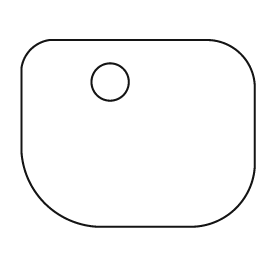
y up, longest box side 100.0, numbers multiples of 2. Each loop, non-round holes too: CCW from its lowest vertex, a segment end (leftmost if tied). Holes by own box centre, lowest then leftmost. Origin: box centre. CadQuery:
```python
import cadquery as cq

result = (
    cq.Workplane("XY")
    .moveTo(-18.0, -40.0)
    .lineTo(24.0, -40.0)
    .threePointArc((42.0, -32.0), (50.0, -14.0))
    .lineTo(50.0, 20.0)
    .threePointArc((44.0, 34.0), (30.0, 40.0))
    .lineTo(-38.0, 40.0)
    .threePointArc((-46.0, 36.0), (-50.0, 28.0))
    .lineTo(-50.0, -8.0)
    .threePointArc((-40.0, -30.0), (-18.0, -40.0))
    .close()
    .moveTo(-12.0, 22.0)
    .circle(8.0)
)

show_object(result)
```